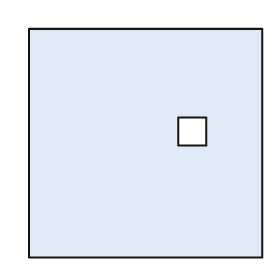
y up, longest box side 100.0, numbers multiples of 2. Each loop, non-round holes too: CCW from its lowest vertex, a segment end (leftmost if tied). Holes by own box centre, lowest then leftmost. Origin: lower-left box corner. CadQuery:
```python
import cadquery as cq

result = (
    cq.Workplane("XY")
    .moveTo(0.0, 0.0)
    .lineTo(100.0, 0.0)
    .lineTo(100.0, 98.0)
    .lineTo(0.0, 98.0)
    .close()
    .moveTo(64.0, 48.0)
    .lineTo(76.0, 48.0)
    .lineTo(76.0, 60.0)
    .lineTo(64.0, 60.0)
    .close()
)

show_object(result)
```